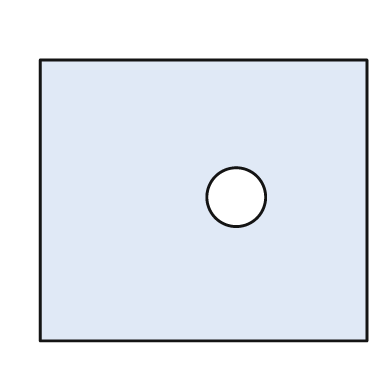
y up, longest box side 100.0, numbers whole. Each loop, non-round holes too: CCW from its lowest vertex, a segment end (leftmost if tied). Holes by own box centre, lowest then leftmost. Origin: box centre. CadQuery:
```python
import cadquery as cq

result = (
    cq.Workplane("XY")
    .moveTo(-50.0, -43.0)
    .lineTo(50.0, -43.0)
    .lineTo(50.0, 43.0)
    .lineTo(-50.0, 43.0)
    .close()
    .moveTo(10.0, 1.0)
    .circle(9.0)
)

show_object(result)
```